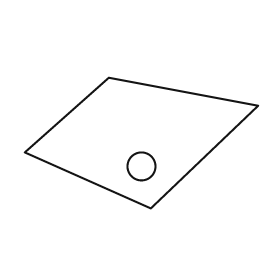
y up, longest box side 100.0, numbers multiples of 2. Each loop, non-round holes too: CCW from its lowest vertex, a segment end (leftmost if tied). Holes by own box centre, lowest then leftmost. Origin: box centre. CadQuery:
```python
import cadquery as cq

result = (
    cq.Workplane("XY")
    .moveTo(4.0, -28.0)
    .lineTo(50.0, 16.0)
    .lineTo(-14.0, 28.0)
    .lineTo(-50.0, -4.0)
    .close()
    .moveTo(0.0, -10.0)
    .circle(6.0)
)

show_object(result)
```